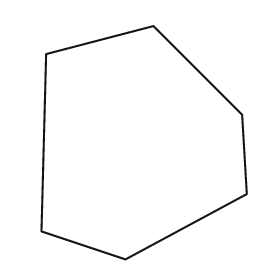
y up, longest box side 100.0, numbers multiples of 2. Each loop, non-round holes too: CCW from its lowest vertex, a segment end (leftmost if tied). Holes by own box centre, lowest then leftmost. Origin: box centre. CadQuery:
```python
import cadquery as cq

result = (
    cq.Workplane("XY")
    .moveTo(-8.0, -50.0)
    .lineTo(44.0, -22.0)
    .lineTo(42.0, 12.0)
    .lineTo(4.0, 50.0)
    .lineTo(-42.0, 38.0)
    .lineTo(-44.0, -38.0)
    .close()
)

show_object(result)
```